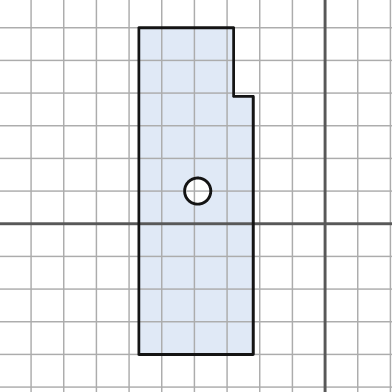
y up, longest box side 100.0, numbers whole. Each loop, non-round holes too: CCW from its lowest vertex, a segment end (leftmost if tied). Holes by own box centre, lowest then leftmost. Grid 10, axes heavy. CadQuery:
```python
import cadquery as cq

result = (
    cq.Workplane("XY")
    .moveTo(-57.0, -40.0)
    .lineTo(-22.0, -40.0)
    .lineTo(-22.0, 39.0)
    .lineTo(-28.0, 39.0)
    .lineTo(-28.0, 60.0)
    .lineTo(-57.0, 60.0)
    .close()
    .moveTo(-39.0, 10.0)
    .circle(4.0)
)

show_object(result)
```